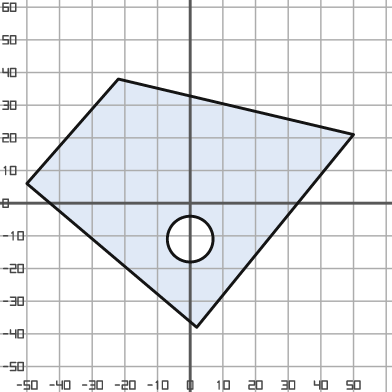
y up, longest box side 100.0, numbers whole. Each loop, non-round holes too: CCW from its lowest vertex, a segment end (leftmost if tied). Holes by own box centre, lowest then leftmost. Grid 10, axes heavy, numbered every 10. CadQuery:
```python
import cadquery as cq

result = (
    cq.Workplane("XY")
    .moveTo(2.0, -38.0)
    .lineTo(50.0, 21.0)
    .lineTo(-22.0, 38.0)
    .lineTo(-50.0, 6.0)
    .close()
    .moveTo(0.0, -11.0)
    .circle(7.0)
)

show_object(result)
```